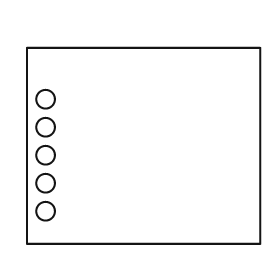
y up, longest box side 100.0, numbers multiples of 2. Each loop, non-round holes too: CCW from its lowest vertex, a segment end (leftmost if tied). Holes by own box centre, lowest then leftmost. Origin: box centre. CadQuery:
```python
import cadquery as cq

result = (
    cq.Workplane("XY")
    .moveTo(-50.0, -42.0)
    .lineTo(50.0, -42.0)
    .lineTo(50.0, 42.0)
    .lineTo(-50.0, 42.0)
    .close()
    .moveTo(-42.0, -28.0)
    .circle(4.0)
    .moveTo(-42.0, -16.0)
    .circle(4.0)
    .moveTo(-42.0, -4.0)
    .circle(4.0)
    .moveTo(-42.0, 8.0)
    .circle(4.0)
    .moveTo(-42.0, 20.0)
    .circle(4.0)
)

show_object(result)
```